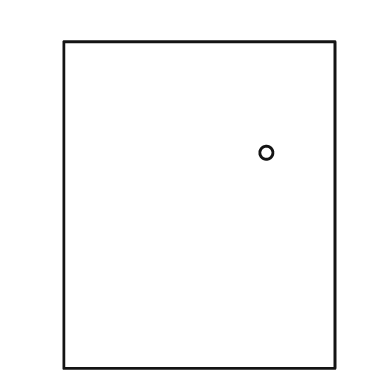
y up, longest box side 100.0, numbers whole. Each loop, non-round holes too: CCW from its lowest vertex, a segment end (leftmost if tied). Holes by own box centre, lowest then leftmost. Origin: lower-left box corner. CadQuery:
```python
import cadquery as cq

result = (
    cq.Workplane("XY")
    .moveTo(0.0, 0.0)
    .lineTo(83.0, 0.0)
    .lineTo(83.0, 100.0)
    .lineTo(0.0, 100.0)
    .close()
    .moveTo(62.0, 66.0)
    .circle(2.0)
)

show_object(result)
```